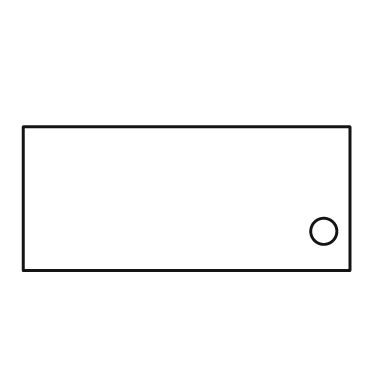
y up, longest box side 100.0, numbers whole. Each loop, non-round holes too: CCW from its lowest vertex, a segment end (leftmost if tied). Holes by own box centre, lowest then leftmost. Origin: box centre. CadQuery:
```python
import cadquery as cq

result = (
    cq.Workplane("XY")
    .moveTo(-50.0, -22.0)
    .lineTo(50.0, -22.0)
    .lineTo(50.0, 22.0)
    .lineTo(-50.0, 22.0)
    .close()
    .moveTo(42.0, -10.0)
    .circle(4.0)
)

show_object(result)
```